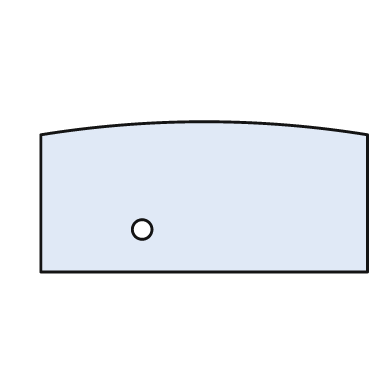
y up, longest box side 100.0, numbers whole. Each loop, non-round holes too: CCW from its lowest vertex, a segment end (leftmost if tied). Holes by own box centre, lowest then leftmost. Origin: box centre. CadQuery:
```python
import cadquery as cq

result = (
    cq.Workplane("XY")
    .moveTo(-50.0, -23.0)
    .lineTo(50.0, -23.0)
    .lineTo(50.0, 19.0)
    .threePointArc((0.0, 23.0), (-50.0, 19.0))
    .close()
    .moveTo(-19.0, -10.0)
    .circle(3.0)
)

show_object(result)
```